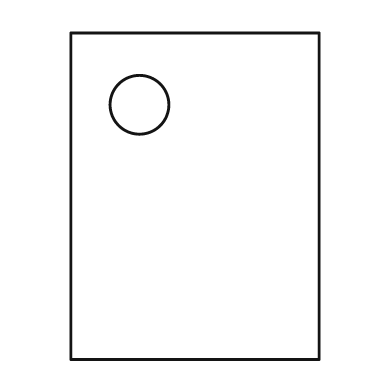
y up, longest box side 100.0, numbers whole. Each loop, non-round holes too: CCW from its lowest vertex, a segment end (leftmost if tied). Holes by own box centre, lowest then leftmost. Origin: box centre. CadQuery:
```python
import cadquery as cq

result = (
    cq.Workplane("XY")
    .moveTo(-38.0, -50.0)
    .lineTo(38.0, -50.0)
    .lineTo(38.0, 50.0)
    .lineTo(-38.0, 50.0)
    .close()
    .moveTo(-17.0, 28.0)
    .circle(9.0)
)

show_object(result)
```